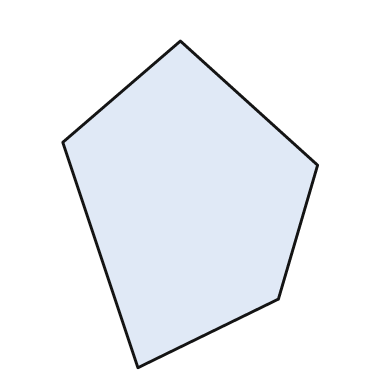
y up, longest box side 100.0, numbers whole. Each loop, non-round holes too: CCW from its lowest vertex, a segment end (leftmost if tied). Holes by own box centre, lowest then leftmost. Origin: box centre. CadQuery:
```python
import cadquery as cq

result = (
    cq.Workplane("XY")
    .moveTo(-16.0, -50.0)
    .lineTo(27.0, -29.0)
    .lineTo(39.0, 12.0)
    .lineTo(-3.0, 50.0)
    .lineTo(-39.0, 19.0)
    .close()
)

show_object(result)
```